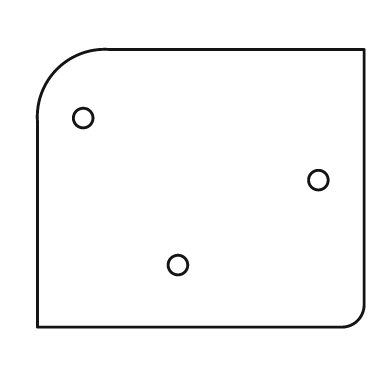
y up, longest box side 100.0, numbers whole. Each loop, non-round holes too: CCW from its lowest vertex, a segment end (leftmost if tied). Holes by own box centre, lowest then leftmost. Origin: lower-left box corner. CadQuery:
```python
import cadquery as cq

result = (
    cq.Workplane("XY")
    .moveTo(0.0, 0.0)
    .lineTo(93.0, 0.0)
    .threePointArc((98.0, 2.0), (100.0, 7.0))
    .lineTo(100.0, 85.0)
    .lineTo(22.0, 85.0)
    .threePointArc((6.0, 79.0), (0.0, 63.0))
    .close()
    .moveTo(43.0, 19.0)
    .circle(3.0)
    .moveTo(86.0, 45.0)
    .circle(3.0)
    .moveTo(14.0, 64.0)
    .circle(3.0)
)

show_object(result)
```